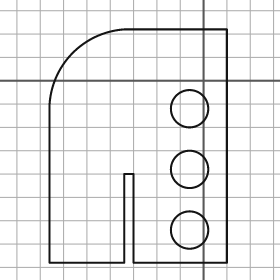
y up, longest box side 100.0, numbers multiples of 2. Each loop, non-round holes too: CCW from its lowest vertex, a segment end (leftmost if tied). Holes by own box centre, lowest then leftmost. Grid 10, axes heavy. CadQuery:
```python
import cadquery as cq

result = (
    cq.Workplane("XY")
    .moveTo(-66.0, -78.0)
    .lineTo(-34.0, -78.0)
    .lineTo(-34.0, -40.0)
    .lineTo(-30.0, -40.0)
    .lineTo(-30.0, -78.0)
    .lineTo(10.0, -78.0)
    .lineTo(10.0, 22.0)
    .lineTo(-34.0, 22.0)
    .threePointArc((-56.0, 12.0), (-66.0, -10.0))
    .close()
    .moveTo(-6.0, -64.0)
    .circle(8.0)
    .moveTo(-6.0, -38.0)
    .circle(8.0)
    .moveTo(-6.0, -12.0)
    .circle(8.0)
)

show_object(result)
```